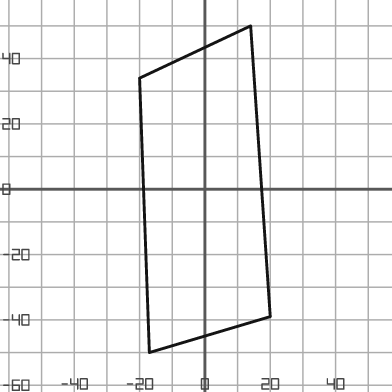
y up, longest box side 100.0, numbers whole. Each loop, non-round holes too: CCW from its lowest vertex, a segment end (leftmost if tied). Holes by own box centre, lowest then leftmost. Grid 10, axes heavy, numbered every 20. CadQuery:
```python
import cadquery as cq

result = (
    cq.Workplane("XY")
    .moveTo(-17.0, -50.0)
    .lineTo(20.0, -39.0)
    .lineTo(14.0, 50.0)
    .lineTo(-20.0, 34.0)
    .close()
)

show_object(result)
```